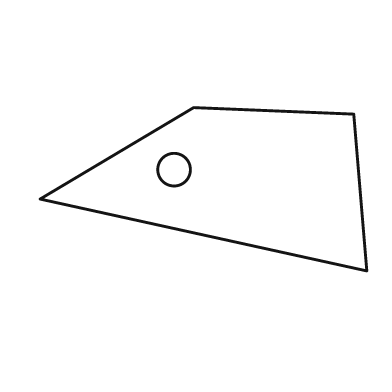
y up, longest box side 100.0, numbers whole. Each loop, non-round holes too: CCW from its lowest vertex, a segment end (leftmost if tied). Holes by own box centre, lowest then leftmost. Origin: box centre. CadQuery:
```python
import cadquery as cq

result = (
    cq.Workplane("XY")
    .moveTo(50.0, -25.0)
    .lineTo(46.0, 23.0)
    .lineTo(-3.0, 25.0)
    .lineTo(-50.0, -3.0)
    .close()
    .moveTo(-9.0, 6.0)
    .circle(5.0)
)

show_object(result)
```